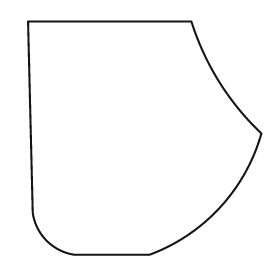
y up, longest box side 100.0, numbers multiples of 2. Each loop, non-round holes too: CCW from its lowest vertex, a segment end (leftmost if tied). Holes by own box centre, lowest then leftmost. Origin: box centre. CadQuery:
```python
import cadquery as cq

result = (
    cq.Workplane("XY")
    .moveTo(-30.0, -50.0)
    .lineTo(2.0, -50.0)
    .threePointArc((32.0, -30.0), (50.0, 2.0))
    .threePointArc((32.0, 24.0), (20.0, 50.0))
    .lineTo(-50.0, 50.0)
    .lineTo(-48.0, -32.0)
    .threePointArc((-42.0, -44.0), (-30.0, -50.0))
    .close()
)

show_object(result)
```